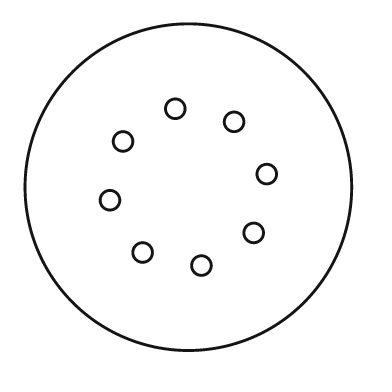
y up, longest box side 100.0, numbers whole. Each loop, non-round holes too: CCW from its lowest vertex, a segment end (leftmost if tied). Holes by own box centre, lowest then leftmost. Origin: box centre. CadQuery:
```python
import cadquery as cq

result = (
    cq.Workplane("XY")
    .moveTo(0.0, 0.0)
    .circle(50.0)
    .moveTo(4.0, -24.0)
    .circle(3.0)
    .moveTo(-14.0, -20.0)
    .circle(3.0)
    .moveTo(20.0, -14.0)
    .circle(3.0)
    .moveTo(-24.0, -4.0)
    .circle(3.0)
    .moveTo(24.0, 4.0)
    .circle(3.0)
    .moveTo(-20.0, 14.0)
    .circle(3.0)
    .moveTo(14.0, 20.0)
    .circle(3.0)
    .moveTo(-4.0, 24.0)
    .circle(3.0)
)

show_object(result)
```